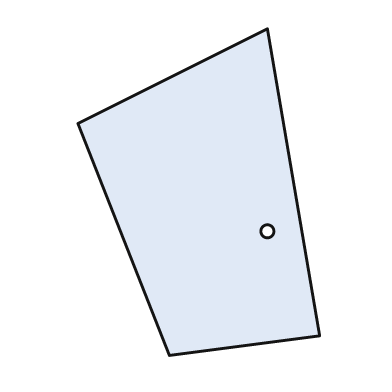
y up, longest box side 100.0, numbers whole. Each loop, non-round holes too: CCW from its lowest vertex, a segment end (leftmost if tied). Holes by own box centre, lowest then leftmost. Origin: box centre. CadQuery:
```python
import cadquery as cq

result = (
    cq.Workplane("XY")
    .moveTo(-9.0, -50.0)
    .lineTo(37.0, -44.0)
    .lineTo(21.0, 50.0)
    .lineTo(-37.0, 21.0)
    .close()
    .moveTo(21.0, -12.0)
    .circle(2.0)
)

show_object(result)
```